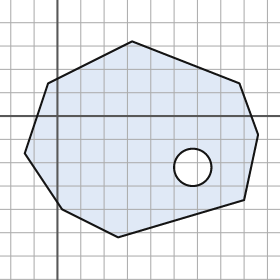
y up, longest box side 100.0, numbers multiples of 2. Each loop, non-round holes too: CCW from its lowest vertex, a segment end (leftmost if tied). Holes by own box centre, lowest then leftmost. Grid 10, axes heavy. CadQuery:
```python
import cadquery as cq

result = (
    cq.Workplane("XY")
    .moveTo(26.0, -52.0)
    .lineTo(80.0, -36.0)
    .lineTo(86.0, -8.0)
    .lineTo(78.0, 14.0)
    .lineTo(32.0, 32.0)
    .lineTo(-4.0, 14.0)
    .lineTo(-14.0, -16.0)
    .lineTo(2.0, -40.0)
    .close()
    .moveTo(58.0, -22.0)
    .circle(8.0)
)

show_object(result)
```